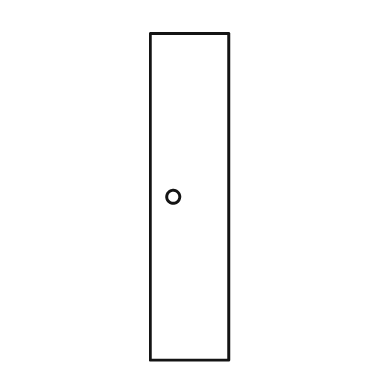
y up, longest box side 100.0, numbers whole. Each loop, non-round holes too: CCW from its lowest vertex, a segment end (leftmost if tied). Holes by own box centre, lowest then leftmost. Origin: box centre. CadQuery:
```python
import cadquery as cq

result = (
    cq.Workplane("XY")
    .moveTo(-12.0, -50.0)
    .lineTo(12.0, -50.0)
    .lineTo(12.0, 50.0)
    .lineTo(-12.0, 50.0)
    .close()
    .moveTo(-5.0, 0.0)
    .circle(2.0)
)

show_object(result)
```